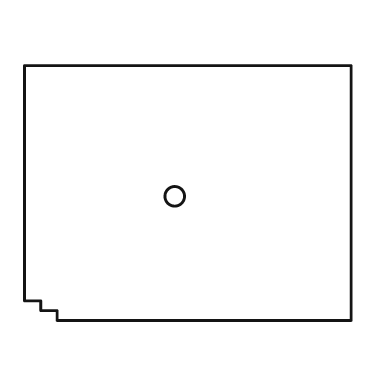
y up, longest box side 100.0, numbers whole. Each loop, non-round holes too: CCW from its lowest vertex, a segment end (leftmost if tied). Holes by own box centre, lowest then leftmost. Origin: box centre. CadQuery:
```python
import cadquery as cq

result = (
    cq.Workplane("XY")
    .moveTo(-40.0, -39.0)
    .lineTo(50.0, -39.0)
    .lineTo(50.0, 39.0)
    .lineTo(-50.0, 39.0)
    .lineTo(-50.0, -33.0)
    .lineTo(-45.0, -33.0)
    .lineTo(-45.0, -36.0)
    .lineTo(-40.0, -36.0)
    .close()
    .moveTo(-4.0, -1.0)
    .circle(3.0)
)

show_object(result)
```